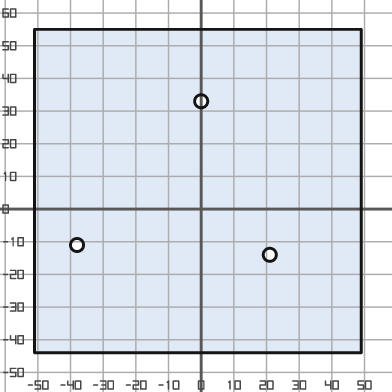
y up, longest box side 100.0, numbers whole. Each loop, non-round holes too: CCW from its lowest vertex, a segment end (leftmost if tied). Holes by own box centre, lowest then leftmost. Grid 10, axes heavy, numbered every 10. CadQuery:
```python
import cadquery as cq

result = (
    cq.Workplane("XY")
    .moveTo(-51.0, -44.0)
    .lineTo(49.0, -44.0)
    .lineTo(49.0, 55.0)
    .lineTo(-51.0, 55.0)
    .close()
    .moveTo(21.0, -14.0)
    .circle(2.0)
    .moveTo(-38.0, -11.0)
    .circle(2.0)
    .moveTo(0.0, 33.0)
    .circle(2.0)
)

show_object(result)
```